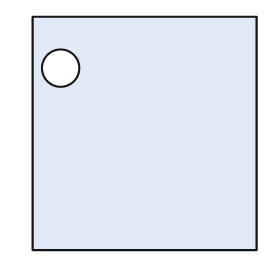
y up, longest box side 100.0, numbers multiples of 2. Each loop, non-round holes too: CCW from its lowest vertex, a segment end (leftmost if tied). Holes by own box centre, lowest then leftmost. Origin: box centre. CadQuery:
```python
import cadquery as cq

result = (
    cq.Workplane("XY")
    .moveTo(-48.0, -50.0)
    .lineTo(48.0, -50.0)
    .lineTo(48.0, 50.0)
    .lineTo(-48.0, 50.0)
    .close()
    .moveTo(-36.0, 28.0)
    .circle(8.0)
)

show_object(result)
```